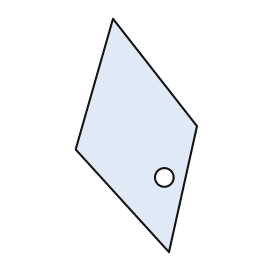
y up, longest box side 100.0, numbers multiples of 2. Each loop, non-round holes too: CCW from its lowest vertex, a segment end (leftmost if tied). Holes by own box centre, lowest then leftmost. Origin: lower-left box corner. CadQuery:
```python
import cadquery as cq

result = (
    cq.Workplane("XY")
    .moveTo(40.0, 0.0)
    .lineTo(52.0, 54.0)
    .lineTo(16.0, 100.0)
    .lineTo(0.0, 44.0)
    .close()
    .moveTo(38.0, 32.0)
    .circle(4.0)
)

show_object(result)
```